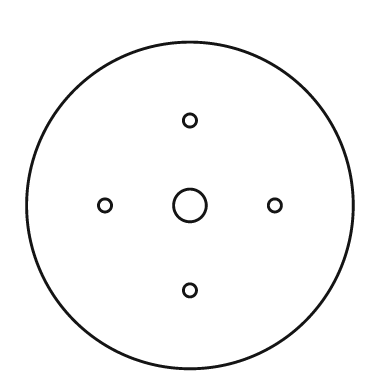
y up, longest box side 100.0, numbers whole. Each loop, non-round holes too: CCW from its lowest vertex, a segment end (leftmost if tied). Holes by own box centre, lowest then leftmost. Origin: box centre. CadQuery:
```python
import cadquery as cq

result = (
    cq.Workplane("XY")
    .moveTo(0.0, 0.0)
    .circle(50.0)
    .moveTo(0.0, -26.0)
    .circle(2.0)
    .moveTo(-26.0, 0.0)
    .circle(2.0)
    .moveTo(0.0, 0.0)
    .circle(5.0)
    .moveTo(26.0, 0.0)
    .circle(2.0)
    .moveTo(0.0, 26.0)
    .circle(2.0)
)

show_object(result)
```